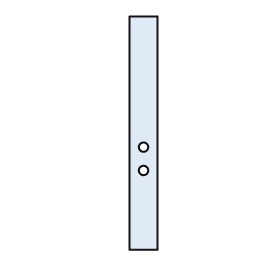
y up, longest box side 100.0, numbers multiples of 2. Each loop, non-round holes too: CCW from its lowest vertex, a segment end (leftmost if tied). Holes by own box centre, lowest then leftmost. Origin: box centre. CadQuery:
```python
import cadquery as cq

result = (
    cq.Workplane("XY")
    .moveTo(-6.0, -50.0)
    .lineTo(6.0, -50.0)
    .lineTo(6.0, 50.0)
    .lineTo(-6.0, 50.0)
    .close()
    .moveTo(0.0, -16.0)
    .circle(2.0)
    .moveTo(0.0, -6.0)
    .circle(2.0)
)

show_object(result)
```